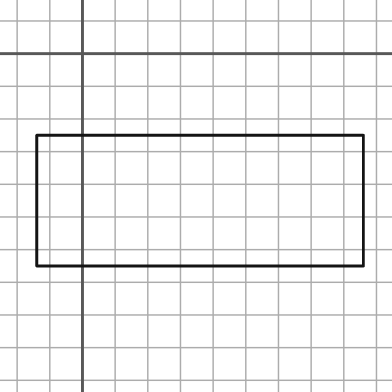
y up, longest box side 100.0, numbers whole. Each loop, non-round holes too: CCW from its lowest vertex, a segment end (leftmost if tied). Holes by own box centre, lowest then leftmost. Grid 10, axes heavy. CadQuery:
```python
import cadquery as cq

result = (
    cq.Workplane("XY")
    .moveTo(-14.0, -65.0)
    .lineTo(86.0, -65.0)
    .lineTo(86.0, -25.0)
    .lineTo(-14.0, -25.0)
    .close()
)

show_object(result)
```